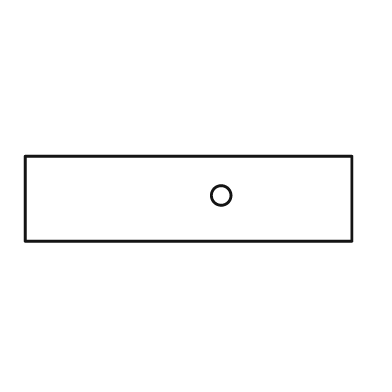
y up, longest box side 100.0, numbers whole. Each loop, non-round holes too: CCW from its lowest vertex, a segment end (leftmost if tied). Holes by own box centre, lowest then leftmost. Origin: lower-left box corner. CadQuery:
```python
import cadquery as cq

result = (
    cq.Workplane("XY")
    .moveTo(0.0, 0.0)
    .lineTo(100.0, 0.0)
    .lineTo(100.0, 26.0)
    .lineTo(0.0, 26.0)
    .close()
    .moveTo(60.0, 14.0)
    .circle(3.0)
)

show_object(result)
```